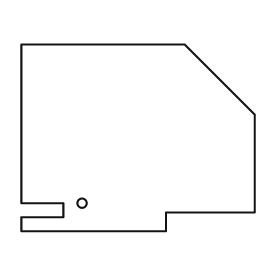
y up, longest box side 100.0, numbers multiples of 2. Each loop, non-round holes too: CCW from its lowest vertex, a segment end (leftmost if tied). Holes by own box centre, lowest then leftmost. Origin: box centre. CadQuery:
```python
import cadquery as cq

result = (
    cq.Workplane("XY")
    .moveTo(-50.0, -40.0)
    .lineTo(12.0, -40.0)
    .lineTo(12.0, -32.0)
    .lineTo(50.0, -32.0)
    .lineTo(50.0, 10.0)
    .lineTo(20.0, 40.0)
    .lineTo(-50.0, 40.0)
    .lineTo(-50.0, -28.0)
    .lineTo(-32.0, -28.0)
    .lineTo(-32.0, -34.0)
    .lineTo(-50.0, -34.0)
    .close()
    .moveTo(-24.0, -28.0)
    .circle(2.0)
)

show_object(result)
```